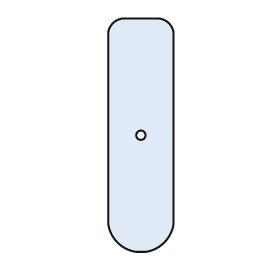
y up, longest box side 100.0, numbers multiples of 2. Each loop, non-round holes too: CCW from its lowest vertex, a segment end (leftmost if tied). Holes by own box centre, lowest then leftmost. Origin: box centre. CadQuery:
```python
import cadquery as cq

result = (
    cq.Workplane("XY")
    .moveTo(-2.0, -50.0)
    .lineTo(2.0, -50.0)
    .threePointArc((10.0, -46.0), (14.0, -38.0))
    .lineTo(14.0, 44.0)
    .threePointArc((12.0, 48.0), (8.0, 50.0))
    .lineTo(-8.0, 50.0)
    .threePointArc((-12.0, 48.0), (-14.0, 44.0))
    .lineTo(-14.0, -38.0)
    .threePointArc((-10.0, -46.0), (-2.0, -50.0))
    .close()
    .moveTo(0.0, 0.0)
    .circle(2.0)
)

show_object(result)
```